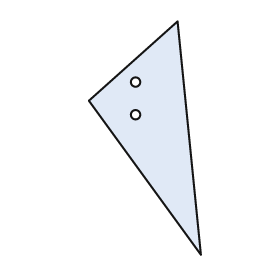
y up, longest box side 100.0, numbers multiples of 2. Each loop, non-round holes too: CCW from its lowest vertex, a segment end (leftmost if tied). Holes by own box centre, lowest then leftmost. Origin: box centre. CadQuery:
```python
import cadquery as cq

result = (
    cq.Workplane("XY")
    .moveTo(24.0, -50.0)
    .lineTo(14.0, 50.0)
    .lineTo(-24.0, 16.0)
    .close()
    .moveTo(-4.0, 10.0)
    .circle(2.0)
    .moveTo(-4.0, 24.0)
    .circle(2.0)
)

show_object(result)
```